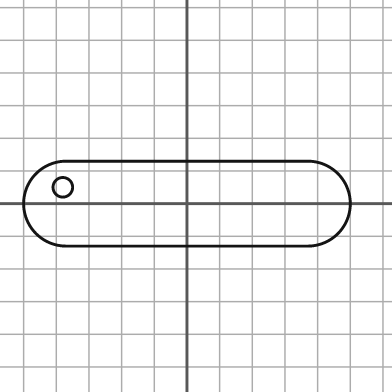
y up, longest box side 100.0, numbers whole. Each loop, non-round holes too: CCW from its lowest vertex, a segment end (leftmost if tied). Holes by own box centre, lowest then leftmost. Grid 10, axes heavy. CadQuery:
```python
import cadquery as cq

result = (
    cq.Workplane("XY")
    .moveTo(-37.0, -13.0)
    .lineTo(37.0, -13.0)
    .threePointArc((50.0, 0.0), (37.0, 13.0))
    .lineTo(-37.0, 13.0)
    .threePointArc((-50.0, 0.0), (-37.0, -13.0))
    .close()
    .moveTo(-38.0, 5.0)
    .circle(3.0)
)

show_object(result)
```